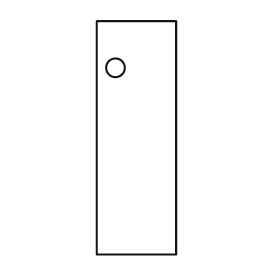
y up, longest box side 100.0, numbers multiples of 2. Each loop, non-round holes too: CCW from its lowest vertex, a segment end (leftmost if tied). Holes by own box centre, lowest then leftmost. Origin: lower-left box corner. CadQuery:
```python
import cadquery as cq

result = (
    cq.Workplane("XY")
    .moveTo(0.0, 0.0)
    .lineTo(34.0, 0.0)
    .lineTo(34.0, 100.0)
    .lineTo(0.0, 100.0)
    .close()
    .moveTo(8.0, 80.0)
    .circle(4.0)
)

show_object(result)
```